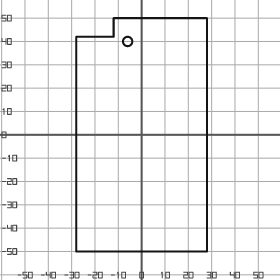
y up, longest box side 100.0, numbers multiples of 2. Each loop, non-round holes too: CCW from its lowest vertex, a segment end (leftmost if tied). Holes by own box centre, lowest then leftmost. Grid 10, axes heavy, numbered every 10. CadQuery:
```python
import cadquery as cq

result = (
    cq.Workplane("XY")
    .moveTo(-28.0, -50.0)
    .lineTo(28.0, -50.0)
    .lineTo(28.0, 50.0)
    .lineTo(-12.0, 50.0)
    .lineTo(-12.0, 42.0)
    .lineTo(-28.0, 42.0)
    .close()
    .moveTo(-6.0, 40.0)
    .circle(2.0)
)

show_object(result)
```